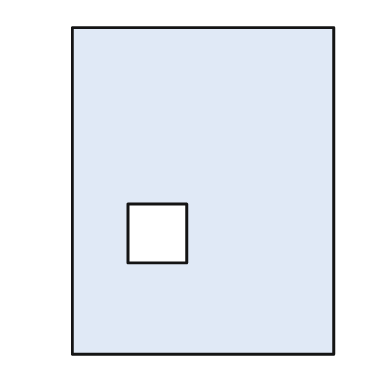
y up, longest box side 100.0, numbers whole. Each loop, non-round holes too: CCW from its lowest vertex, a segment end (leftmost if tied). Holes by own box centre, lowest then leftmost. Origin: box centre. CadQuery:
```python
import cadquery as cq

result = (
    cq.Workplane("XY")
    .moveTo(-40.0, -50.0)
    .lineTo(40.0, -50.0)
    .lineTo(40.0, 50.0)
    .lineTo(-40.0, 50.0)
    .close()
    .moveTo(-23.0, -22.0)
    .lineTo(-5.0, -22.0)
    .lineTo(-5.0, -4.0)
    .lineTo(-23.0, -4.0)
    .close()
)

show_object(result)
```